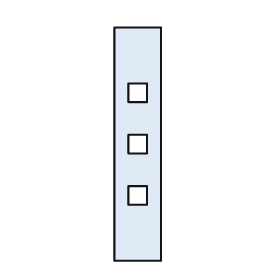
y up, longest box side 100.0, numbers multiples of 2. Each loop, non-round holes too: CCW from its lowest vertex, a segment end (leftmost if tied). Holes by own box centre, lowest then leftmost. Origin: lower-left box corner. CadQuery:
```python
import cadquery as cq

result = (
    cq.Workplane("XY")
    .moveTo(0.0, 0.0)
    .lineTo(20.0, 0.0)
    .lineTo(20.0, 100.0)
    .lineTo(0.0, 100.0)
    .close()
    .moveTo(6.0, 24.0)
    .lineTo(14.0, 24.0)
    .lineTo(14.0, 32.0)
    .lineTo(6.0, 32.0)
    .close()
    .moveTo(6.0, 46.0)
    .lineTo(14.0, 46.0)
    .lineTo(14.0, 54.0)
    .lineTo(6.0, 54.0)
    .close()
    .moveTo(6.0, 68.0)
    .lineTo(14.0, 68.0)
    .lineTo(14.0, 76.0)
    .lineTo(6.0, 76.0)
    .close()
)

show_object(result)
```